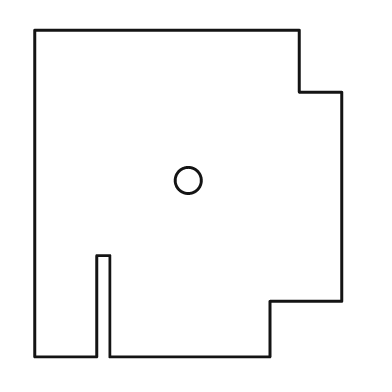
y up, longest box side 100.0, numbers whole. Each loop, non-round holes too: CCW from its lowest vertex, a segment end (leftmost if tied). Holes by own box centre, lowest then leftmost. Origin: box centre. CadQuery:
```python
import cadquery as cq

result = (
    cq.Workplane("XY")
    .moveTo(-47.0, -50.0)
    .lineTo(-28.0, -50.0)
    .lineTo(-28.0, -19.0)
    .lineTo(-24.0, -19.0)
    .lineTo(-24.0, -50.0)
    .lineTo(25.0, -50.0)
    .lineTo(25.0, -33.0)
    .lineTo(47.0, -33.0)
    .lineTo(47.0, 31.0)
    .lineTo(34.0, 31.0)
    .lineTo(34.0, 50.0)
    .lineTo(-47.0, 50.0)
    .close()
    .moveTo(0.0, 4.0)
    .circle(4.0)
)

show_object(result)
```